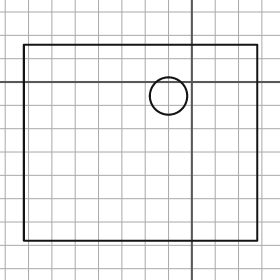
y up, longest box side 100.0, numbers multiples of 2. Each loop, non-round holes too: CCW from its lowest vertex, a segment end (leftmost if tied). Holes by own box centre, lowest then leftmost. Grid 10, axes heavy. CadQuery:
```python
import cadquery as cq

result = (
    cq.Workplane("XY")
    .moveTo(-72.0, -68.0)
    .lineTo(28.0, -68.0)
    .lineTo(28.0, 16.0)
    .lineTo(-72.0, 16.0)
    .close()
    .moveTo(-10.0, -6.0)
    .circle(8.0)
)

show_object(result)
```